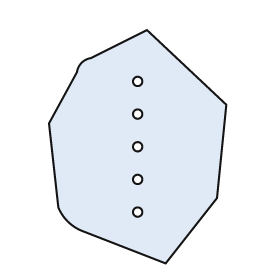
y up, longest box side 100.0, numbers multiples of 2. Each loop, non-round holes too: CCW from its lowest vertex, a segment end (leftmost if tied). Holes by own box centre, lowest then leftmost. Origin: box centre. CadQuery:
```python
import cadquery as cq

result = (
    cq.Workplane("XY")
    .moveTo(12.0, -50.0)
    .lineTo(34.0, -22.0)
    .lineTo(38.0, 18.0)
    .lineTo(4.0, 50.0)
    .lineTo(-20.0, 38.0)
    .threePointArc((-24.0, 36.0), (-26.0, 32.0))
    .lineTo(-38.0, 10.0)
    .lineTo(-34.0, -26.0)
    .threePointArc((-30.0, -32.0), (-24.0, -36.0))
    .close()
    .moveTo(0.0, -28.0)
    .circle(2.0)
    .moveTo(0.0, -14.0)
    .circle(2.0)
    .moveTo(0.0, 0.0)
    .circle(2.0)
    .moveTo(0.0, 14.0)
    .circle(2.0)
    .moveTo(0.0, 28.0)
    .circle(2.0)
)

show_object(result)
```